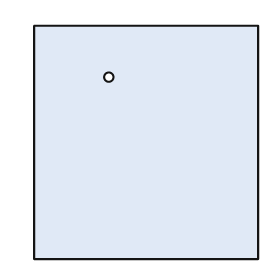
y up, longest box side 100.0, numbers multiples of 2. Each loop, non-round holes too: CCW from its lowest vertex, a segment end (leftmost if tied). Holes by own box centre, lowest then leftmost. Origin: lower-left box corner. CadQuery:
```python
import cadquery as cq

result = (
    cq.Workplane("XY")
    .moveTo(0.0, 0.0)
    .lineTo(96.0, 0.0)
    .lineTo(96.0, 100.0)
    .lineTo(0.0, 100.0)
    .close()
    .moveTo(32.0, 78.0)
    .circle(2.0)
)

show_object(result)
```